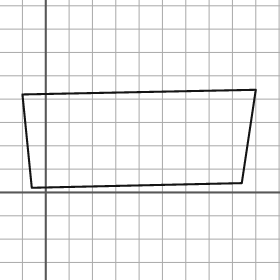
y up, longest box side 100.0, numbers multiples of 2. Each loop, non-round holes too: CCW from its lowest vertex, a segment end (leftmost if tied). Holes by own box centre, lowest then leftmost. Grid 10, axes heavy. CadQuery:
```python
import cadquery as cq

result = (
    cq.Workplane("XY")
    .moveTo(-6.0, 2.0)
    .lineTo(84.0, 4.0)
    .lineTo(90.0, 44.0)
    .lineTo(-10.0, 42.0)
    .close()
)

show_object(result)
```